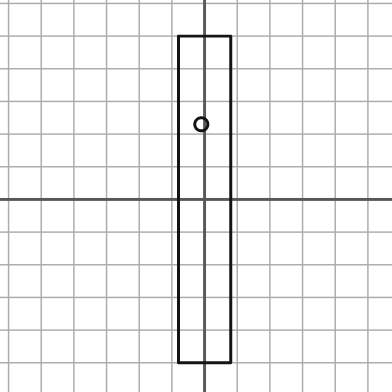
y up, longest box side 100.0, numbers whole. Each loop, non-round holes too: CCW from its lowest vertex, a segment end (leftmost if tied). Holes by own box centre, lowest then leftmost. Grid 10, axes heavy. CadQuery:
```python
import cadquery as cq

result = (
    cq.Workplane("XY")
    .moveTo(-8.0, -50.0)
    .lineTo(8.0, -50.0)
    .lineTo(8.0, 50.0)
    .lineTo(-8.0, 50.0)
    .close()
    .moveTo(-1.0, 23.0)
    .circle(2.0)
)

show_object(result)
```